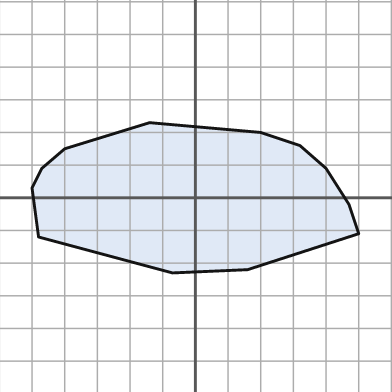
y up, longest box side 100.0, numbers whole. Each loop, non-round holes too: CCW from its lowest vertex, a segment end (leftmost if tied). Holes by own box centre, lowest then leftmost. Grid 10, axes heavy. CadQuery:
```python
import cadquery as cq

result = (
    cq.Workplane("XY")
    .moveTo(-7.0, -23.0)
    .lineTo(16.0, -22.0)
    .lineTo(50.0, -11.0)
    .lineTo(47.0, -2.0)
    .lineTo(40.0, 9.0)
    .lineTo(32.0, 16.0)
    .lineTo(20.0, 20.0)
    .lineTo(-14.0, 23.0)
    .lineTo(-40.0, 15.0)
    .lineTo(-47.0, 9.0)
    .lineTo(-50.0, 3.0)
    .lineTo(-48.0, -12.0)
    .close()
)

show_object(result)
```